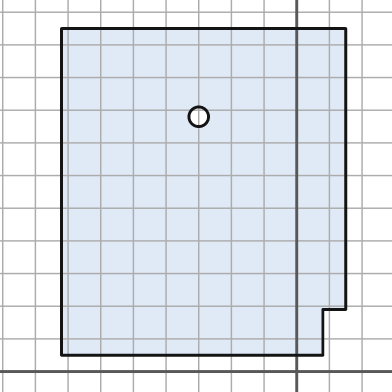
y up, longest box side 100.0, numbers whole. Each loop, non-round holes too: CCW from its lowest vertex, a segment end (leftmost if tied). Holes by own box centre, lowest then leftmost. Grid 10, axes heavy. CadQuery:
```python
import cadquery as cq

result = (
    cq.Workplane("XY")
    .moveTo(-72.0, 5.0)
    .lineTo(8.0, 5.0)
    .lineTo(8.0, 19.0)
    .lineTo(15.0, 19.0)
    .lineTo(15.0, 105.0)
    .lineTo(-72.0, 105.0)
    .close()
    .moveTo(-30.0, 78.0)
    .circle(3.0)
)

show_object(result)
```